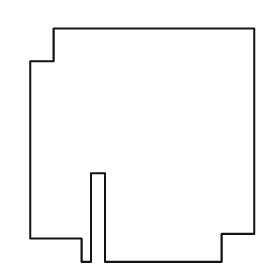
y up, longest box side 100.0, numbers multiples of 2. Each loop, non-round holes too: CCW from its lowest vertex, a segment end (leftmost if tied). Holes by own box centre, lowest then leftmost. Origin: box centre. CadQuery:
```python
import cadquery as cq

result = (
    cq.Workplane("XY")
    .moveTo(-26.0, -50.0)
    .lineTo(-22.0, -50.0)
    .lineTo(-22.0, -12.0)
    .lineTo(-16.0, -12.0)
    .lineTo(-16.0, -50.0)
    .lineTo(34.0, -50.0)
    .lineTo(34.0, -38.0)
    .lineTo(48.0, -38.0)
    .lineTo(48.0, 50.0)
    .lineTo(-38.0, 50.0)
    .lineTo(-38.0, 36.0)
    .lineTo(-48.0, 36.0)
    .lineTo(-48.0, -40.0)
    .lineTo(-26.0, -40.0)
    .close()
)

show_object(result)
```